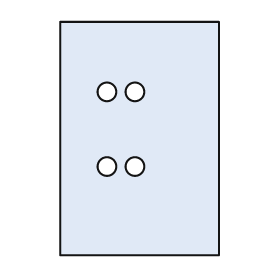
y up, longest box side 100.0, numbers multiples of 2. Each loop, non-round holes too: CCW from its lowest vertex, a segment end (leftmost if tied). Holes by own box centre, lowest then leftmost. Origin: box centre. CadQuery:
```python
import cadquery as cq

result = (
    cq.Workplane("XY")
    .moveTo(-34.0, -50.0)
    .lineTo(34.0, -50.0)
    .lineTo(34.0, 50.0)
    .lineTo(-34.0, 50.0)
    .close()
    .moveTo(-14.0, -12.0)
    .circle(4.0)
    .moveTo(-2.0, -12.0)
    .circle(4.0)
    .moveTo(-14.0, 20.0)
    .circle(4.0)
    .moveTo(-2.0, 20.0)
    .circle(4.0)
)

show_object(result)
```